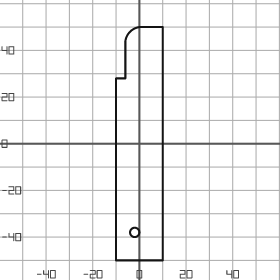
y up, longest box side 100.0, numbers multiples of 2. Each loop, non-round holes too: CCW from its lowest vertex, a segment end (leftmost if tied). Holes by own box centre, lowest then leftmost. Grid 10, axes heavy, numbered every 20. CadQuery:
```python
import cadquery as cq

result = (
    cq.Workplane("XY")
    .moveTo(-10.0, -50.0)
    .lineTo(10.0, -50.0)
    .lineTo(10.0, 50.0)
    .lineTo(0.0, 50.0)
    .threePointArc((-4.0, 48.0), (-6.0, 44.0))
    .lineTo(-6.0, 28.0)
    .lineTo(-10.0, 28.0)
    .close()
    .moveTo(-2.0, -38.0)
    .circle(2.0)
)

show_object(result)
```